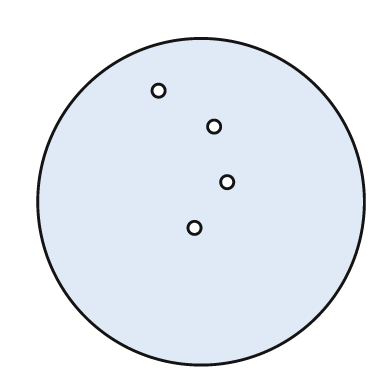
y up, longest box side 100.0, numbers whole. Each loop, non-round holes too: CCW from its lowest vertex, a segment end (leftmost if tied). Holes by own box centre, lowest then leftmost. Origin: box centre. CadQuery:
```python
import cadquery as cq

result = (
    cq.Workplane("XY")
    .moveTo(0.0, 0.0)
    .circle(50.0)
    .moveTo(-2.0, -8.0)
    .circle(2.0)
    .moveTo(8.0, 6.0)
    .circle(2.0)
    .moveTo(4.0, 23.0)
    .circle(2.0)
    .moveTo(-13.0, 34.0)
    .circle(2.0)
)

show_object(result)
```